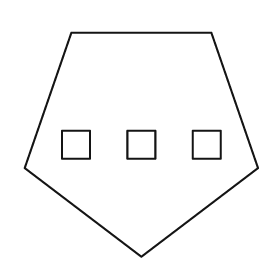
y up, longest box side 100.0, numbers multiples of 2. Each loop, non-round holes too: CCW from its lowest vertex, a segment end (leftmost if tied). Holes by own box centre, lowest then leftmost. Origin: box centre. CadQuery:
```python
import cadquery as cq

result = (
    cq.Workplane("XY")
    .moveTo(0.0, -48.0)
    .lineTo(50.0, -10.0)
    .lineTo(30.0, 48.0)
    .lineTo(-30.0, 48.0)
    .lineTo(-50.0, -10.0)
    .close()
    .moveTo(-34.0, -6.0)
    .lineTo(-22.0, -6.0)
    .lineTo(-22.0, 6.0)
    .lineTo(-34.0, 6.0)
    .close()
    .moveTo(-6.0, -6.0)
    .lineTo(6.0, -6.0)
    .lineTo(6.0, 6.0)
    .lineTo(-6.0, 6.0)
    .close()
    .moveTo(22.0, -6.0)
    .lineTo(34.0, -6.0)
    .lineTo(34.0, 6.0)
    .lineTo(22.0, 6.0)
    .close()
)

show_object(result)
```